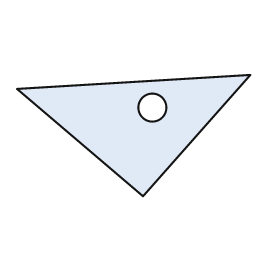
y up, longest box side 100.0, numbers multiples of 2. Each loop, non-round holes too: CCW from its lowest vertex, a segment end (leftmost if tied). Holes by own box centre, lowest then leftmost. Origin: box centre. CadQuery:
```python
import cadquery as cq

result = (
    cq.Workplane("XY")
    .moveTo(4.0, -26.0)
    .lineTo(50.0, 26.0)
    .lineTo(-50.0, 20.0)
    .close()
    .moveTo(8.0, 12.0)
    .circle(6.0)
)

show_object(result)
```